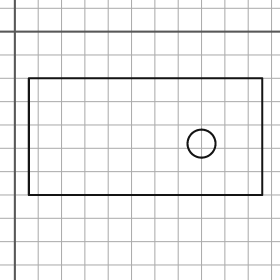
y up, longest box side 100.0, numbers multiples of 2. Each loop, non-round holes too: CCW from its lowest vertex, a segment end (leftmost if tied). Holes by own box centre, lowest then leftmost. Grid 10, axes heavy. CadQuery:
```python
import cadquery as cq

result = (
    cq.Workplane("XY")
    .moveTo(6.0, -70.0)
    .lineTo(106.0, -70.0)
    .lineTo(106.0, -20.0)
    .lineTo(6.0, -20.0)
    .close()
    .moveTo(80.0, -48.0)
    .circle(6.0)
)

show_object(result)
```